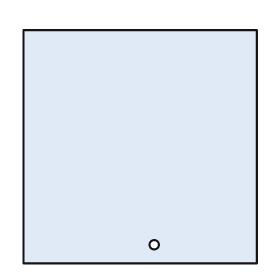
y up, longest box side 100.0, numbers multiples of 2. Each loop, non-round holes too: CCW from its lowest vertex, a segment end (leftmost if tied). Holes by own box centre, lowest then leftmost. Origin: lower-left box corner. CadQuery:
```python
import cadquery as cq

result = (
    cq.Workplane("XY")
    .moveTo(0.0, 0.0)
    .lineTo(100.0, 0.0)
    .lineTo(100.0, 100.0)
    .lineTo(0.0, 100.0)
    .close()
    .moveTo(56.0, 8.0)
    .circle(2.0)
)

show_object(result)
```